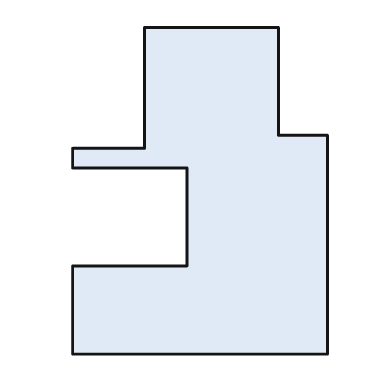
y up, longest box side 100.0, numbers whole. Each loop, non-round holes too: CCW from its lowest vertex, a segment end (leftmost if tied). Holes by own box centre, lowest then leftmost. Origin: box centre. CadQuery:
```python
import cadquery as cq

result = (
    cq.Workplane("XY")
    .moveTo(-39.0, -50.0)
    .lineTo(39.0, -50.0)
    .lineTo(39.0, 17.0)
    .lineTo(24.0, 17.0)
    .lineTo(24.0, 50.0)
    .lineTo(-17.0, 50.0)
    .lineTo(-17.0, 13.0)
    .lineTo(-39.0, 13.0)
    .lineTo(-39.0, 7.0)
    .lineTo(-4.0, 7.0)
    .lineTo(-4.0, -23.0)
    .lineTo(-39.0, -23.0)
    .close()
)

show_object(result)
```